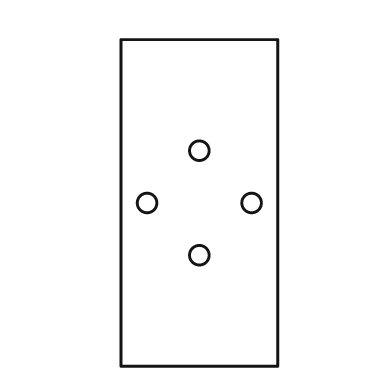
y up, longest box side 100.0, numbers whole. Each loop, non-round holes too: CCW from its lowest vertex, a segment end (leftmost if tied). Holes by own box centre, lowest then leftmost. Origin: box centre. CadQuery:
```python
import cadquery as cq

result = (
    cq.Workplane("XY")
    .moveTo(-24.0, -50.0)
    .lineTo(24.0, -50.0)
    .lineTo(24.0, 50.0)
    .lineTo(-24.0, 50.0)
    .close()
    .moveTo(0.0, -16.0)
    .circle(3.0)
    .moveTo(-16.0, 0.0)
    .circle(3.0)
    .moveTo(16.0, 0.0)
    .circle(3.0)
    .moveTo(0.0, 16.0)
    .circle(3.0)
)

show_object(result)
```